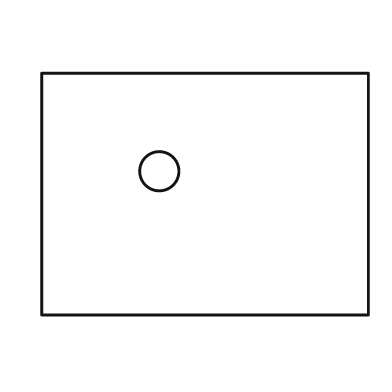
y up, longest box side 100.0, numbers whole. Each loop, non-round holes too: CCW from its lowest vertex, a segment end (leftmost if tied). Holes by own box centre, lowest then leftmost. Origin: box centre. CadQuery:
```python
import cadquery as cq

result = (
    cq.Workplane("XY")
    .moveTo(-50.0, -37.0)
    .lineTo(50.0, -37.0)
    .lineTo(50.0, 37.0)
    .lineTo(-50.0, 37.0)
    .close()
    .moveTo(-14.0, 7.0)
    .circle(6.0)
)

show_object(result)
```